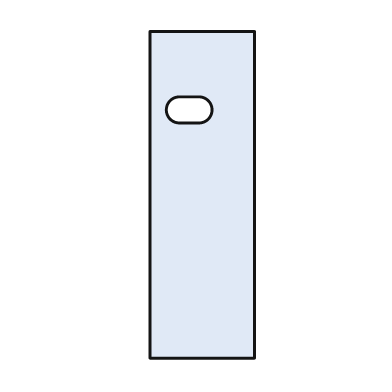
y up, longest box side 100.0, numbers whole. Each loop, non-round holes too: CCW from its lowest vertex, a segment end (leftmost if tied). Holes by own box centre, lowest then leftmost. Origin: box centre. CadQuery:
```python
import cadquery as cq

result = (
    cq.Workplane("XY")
    .moveTo(-16.0, -50.0)
    .lineTo(16.0, -50.0)
    .lineTo(16.0, 50.0)
    .lineTo(-16.0, 50.0)
    .close()
    .moveTo(-7.0, 22.0)
    .lineTo(-1.0, 22.0)
    .threePointArc((3.0, 26.0), (-1.0, 30.0))
    .lineTo(-7.0, 30.0)
    .threePointArc((-11.0, 26.0), (-7.0, 22.0))
    .close()
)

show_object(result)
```